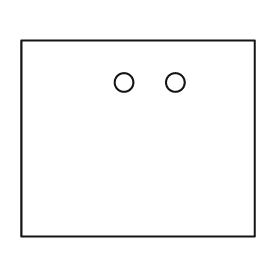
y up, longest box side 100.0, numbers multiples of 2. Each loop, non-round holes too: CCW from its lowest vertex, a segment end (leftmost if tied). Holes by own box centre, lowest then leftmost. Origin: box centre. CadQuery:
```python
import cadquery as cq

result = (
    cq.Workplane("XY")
    .moveTo(-50.0, -42.0)
    .lineTo(50.0, -42.0)
    .lineTo(50.0, 42.0)
    .lineTo(-50.0, 42.0)
    .close()
    .moveTo(-6.0, 24.0)
    .circle(4.0)
    .moveTo(16.0, 24.0)
    .circle(4.0)
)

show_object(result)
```